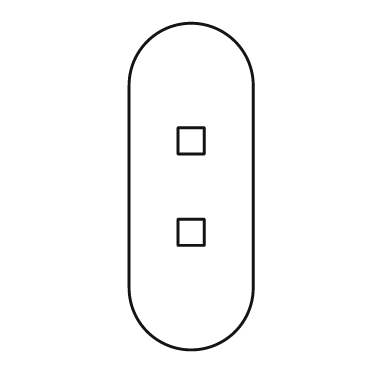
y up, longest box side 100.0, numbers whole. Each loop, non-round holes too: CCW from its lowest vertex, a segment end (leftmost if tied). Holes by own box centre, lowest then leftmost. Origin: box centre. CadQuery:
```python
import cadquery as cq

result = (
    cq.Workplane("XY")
    .moveTo(-19.0, -31.0)
    .threePointArc((0.0, -50.0), (19.0, -31.0))
    .lineTo(19.0, 31.0)
    .threePointArc((0.0, 50.0), (-19.0, 31.0))
    .close()
    .moveTo(-4.0, -18.0)
    .lineTo(4.0, -18.0)
    .lineTo(4.0, -10.0)
    .lineTo(-4.0, -10.0)
    .close()
    .moveTo(-4.0, 10.0)
    .lineTo(4.0, 10.0)
    .lineTo(4.0, 18.0)
    .lineTo(-4.0, 18.0)
    .close()
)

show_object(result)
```